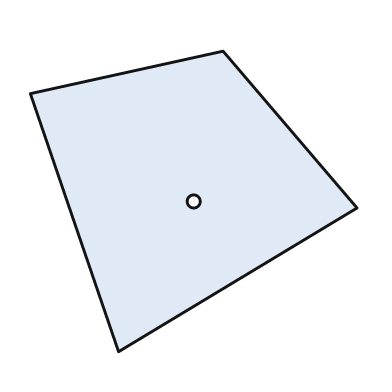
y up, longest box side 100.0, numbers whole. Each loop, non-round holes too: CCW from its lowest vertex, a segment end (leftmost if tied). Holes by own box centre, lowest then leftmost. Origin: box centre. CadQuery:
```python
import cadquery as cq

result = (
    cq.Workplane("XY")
    .moveTo(-23.0, -46.0)
    .lineTo(50.0, -2.0)
    .lineTo(9.0, 46.0)
    .lineTo(-50.0, 33.0)
    .close()
    .moveTo(0.0, 0.0)
    .circle(2.0)
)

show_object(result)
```